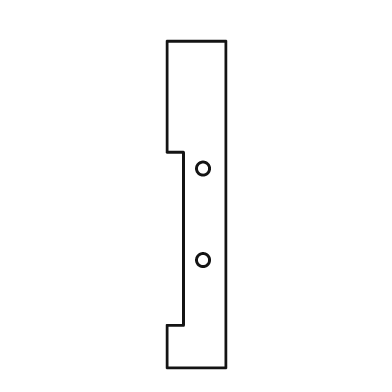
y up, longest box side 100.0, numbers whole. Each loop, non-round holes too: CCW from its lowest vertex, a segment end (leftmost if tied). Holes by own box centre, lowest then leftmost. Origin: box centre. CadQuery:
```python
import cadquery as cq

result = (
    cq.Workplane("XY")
    .moveTo(-9.0, -50.0)
    .lineTo(9.0, -50.0)
    .lineTo(9.0, 50.0)
    .lineTo(-9.0, 50.0)
    .lineTo(-9.0, 16.0)
    .lineTo(-4.0, 16.0)
    .lineTo(-4.0, -37.0)
    .lineTo(-9.0, -37.0)
    .close()
    .moveTo(2.0, -17.0)
    .circle(2.0)
    .moveTo(2.0, 11.0)
    .circle(2.0)
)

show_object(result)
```